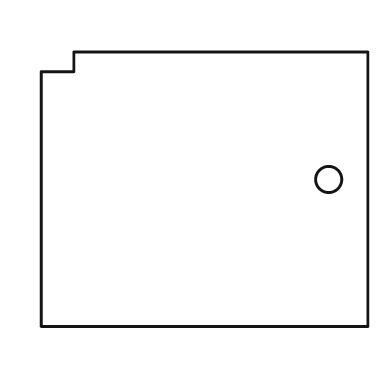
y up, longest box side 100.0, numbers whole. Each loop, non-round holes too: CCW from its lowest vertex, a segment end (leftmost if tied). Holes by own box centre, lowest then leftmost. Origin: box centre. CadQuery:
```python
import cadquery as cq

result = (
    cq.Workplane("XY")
    .moveTo(-50.0, -42.0)
    .lineTo(50.0, -42.0)
    .lineTo(50.0, 42.0)
    .lineTo(-40.0, 42.0)
    .lineTo(-40.0, 36.0)
    .lineTo(-50.0, 36.0)
    .close()
    .moveTo(38.0, 3.0)
    .circle(4.0)
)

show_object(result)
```